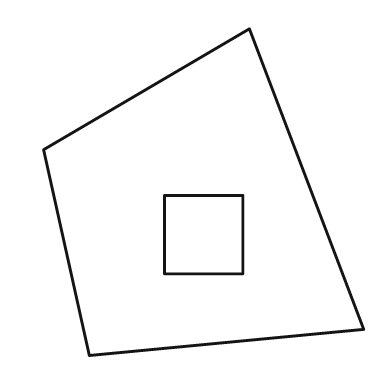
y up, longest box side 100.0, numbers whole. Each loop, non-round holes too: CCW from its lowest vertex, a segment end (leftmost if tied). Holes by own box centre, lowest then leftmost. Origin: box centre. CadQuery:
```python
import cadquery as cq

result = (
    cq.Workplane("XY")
    .moveTo(-35.0, -50.0)
    .lineTo(49.0, -42.0)
    .lineTo(14.0, 50.0)
    .lineTo(-49.0, 13.0)
    .close()
    .moveTo(-12.0, -25.0)
    .lineTo(12.0, -25.0)
    .lineTo(12.0, -1.0)
    .lineTo(-12.0, -1.0)
    .close()
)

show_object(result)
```